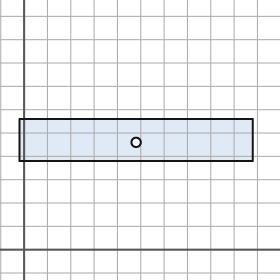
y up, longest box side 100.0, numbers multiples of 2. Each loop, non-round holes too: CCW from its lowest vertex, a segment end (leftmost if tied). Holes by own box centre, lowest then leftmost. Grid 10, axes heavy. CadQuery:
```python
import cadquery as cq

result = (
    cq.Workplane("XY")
    .moveTo(-2.0, 38.0)
    .lineTo(98.0, 38.0)
    .lineTo(98.0, 56.0)
    .lineTo(-2.0, 56.0)
    .close()
    .moveTo(48.0, 46.0)
    .circle(2.0)
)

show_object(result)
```